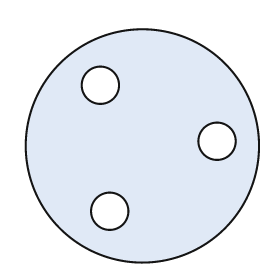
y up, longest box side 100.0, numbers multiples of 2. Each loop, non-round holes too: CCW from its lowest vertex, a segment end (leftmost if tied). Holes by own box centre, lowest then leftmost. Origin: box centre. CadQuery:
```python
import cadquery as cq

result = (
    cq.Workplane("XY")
    .moveTo(0.0, 0.0)
    .circle(50.0)
    .moveTo(-14.0, -28.0)
    .circle(8.0)
    .moveTo(32.0, 2.0)
    .circle(8.0)
    .moveTo(-18.0, 26.0)
    .circle(8.0)
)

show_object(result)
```